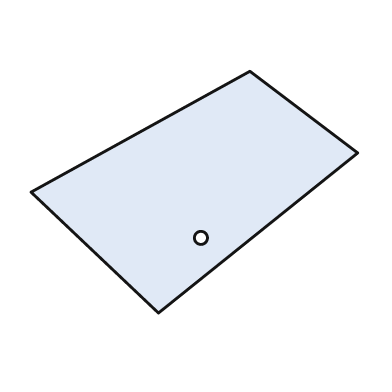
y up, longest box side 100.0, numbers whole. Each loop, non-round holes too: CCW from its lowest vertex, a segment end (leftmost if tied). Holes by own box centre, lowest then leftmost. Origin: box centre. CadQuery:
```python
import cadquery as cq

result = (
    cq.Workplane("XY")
    .moveTo(-11.0, -37.0)
    .lineTo(50.0, 12.0)
    .lineTo(17.0, 37.0)
    .lineTo(-50.0, 0.0)
    .close()
    .moveTo(2.0, -14.0)
    .circle(2.0)
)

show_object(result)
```